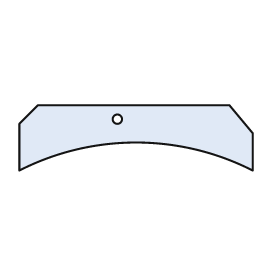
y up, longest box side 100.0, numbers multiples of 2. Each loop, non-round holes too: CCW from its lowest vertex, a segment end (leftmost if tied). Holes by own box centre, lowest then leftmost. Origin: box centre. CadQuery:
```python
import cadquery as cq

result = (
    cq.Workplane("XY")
    .moveTo(-50.0, -14.0)
    .threePointArc((0.0, -2.0), (50.0, -14.0))
    .lineTo(50.0, 2.0)
    .lineTo(40.0, 14.0)
    .lineTo(-42.0, 14.0)
    .lineTo(-50.0, 6.0)
    .close()
    .moveTo(-8.0, 8.0)
    .circle(2.0)
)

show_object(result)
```